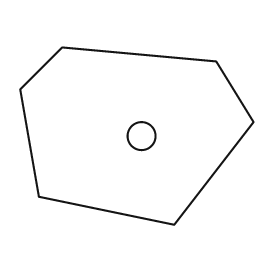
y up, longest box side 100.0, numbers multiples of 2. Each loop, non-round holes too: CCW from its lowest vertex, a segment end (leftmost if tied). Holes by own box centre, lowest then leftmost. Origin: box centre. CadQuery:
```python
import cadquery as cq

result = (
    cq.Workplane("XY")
    .moveTo(16.0, -38.0)
    .lineTo(50.0, 6.0)
    .lineTo(34.0, 32.0)
    .lineTo(-32.0, 38.0)
    .lineTo(-50.0, 20.0)
    .lineTo(-42.0, -26.0)
    .close()
    .moveTo(2.0, 0.0)
    .circle(6.0)
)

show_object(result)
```